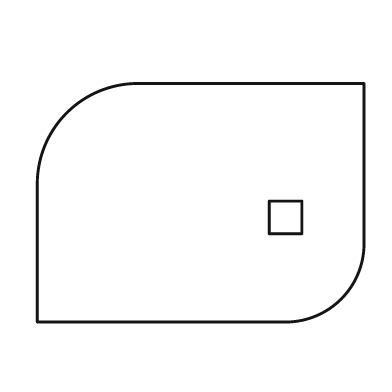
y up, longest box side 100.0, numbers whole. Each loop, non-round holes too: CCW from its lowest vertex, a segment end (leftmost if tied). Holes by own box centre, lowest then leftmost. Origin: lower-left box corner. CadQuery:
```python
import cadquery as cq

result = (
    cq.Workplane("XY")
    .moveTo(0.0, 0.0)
    .lineTo(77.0, 0.0)
    .threePointArc((93.0, 7.0), (100.0, 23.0))
    .lineTo(100.0, 73.0)
    .lineTo(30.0, 73.0)
    .threePointArc((9.0, 64.0), (0.0, 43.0))
    .close()
    .moveTo(71.0, 27.0)
    .lineTo(81.0, 27.0)
    .lineTo(81.0, 37.0)
    .lineTo(71.0, 37.0)
    .close()
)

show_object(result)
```